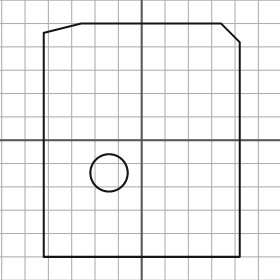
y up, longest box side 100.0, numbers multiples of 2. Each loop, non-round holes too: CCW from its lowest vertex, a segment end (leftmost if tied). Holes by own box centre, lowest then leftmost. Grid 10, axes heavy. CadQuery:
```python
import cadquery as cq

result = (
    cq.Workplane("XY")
    .moveTo(-42.0, -50.0)
    .lineTo(42.0, -50.0)
    .lineTo(42.0, 42.0)
    .lineTo(34.0, 50.0)
    .lineTo(-26.0, 50.0)
    .lineTo(-42.0, 46.0)
    .close()
    .moveTo(-14.0, -14.0)
    .circle(8.0)
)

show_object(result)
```